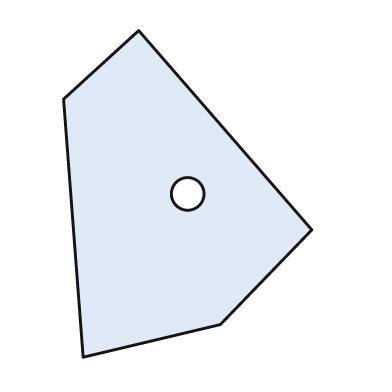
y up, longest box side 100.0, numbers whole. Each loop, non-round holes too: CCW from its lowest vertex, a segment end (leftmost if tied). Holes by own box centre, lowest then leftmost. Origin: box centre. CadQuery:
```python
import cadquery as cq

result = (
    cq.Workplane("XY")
    .moveTo(-32.0, -50.0)
    .lineTo(10.0, -40.0)
    .lineTo(38.0, -11.0)
    .lineTo(-15.0, 50.0)
    .lineTo(-38.0, 29.0)
    .close()
    .moveTo(0.0, 0.0)
    .circle(5.0)
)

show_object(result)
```